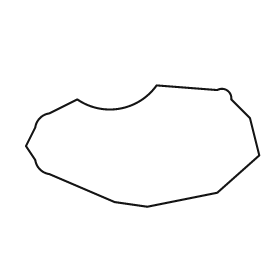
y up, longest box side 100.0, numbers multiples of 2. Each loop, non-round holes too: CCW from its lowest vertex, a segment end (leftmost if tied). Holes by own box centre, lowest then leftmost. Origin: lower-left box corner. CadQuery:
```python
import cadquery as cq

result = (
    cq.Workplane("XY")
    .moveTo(52.0, 0.0)
    .lineTo(82.0, 6.0)
    .lineTo(100.0, 22.0)
    .lineTo(96.0, 38.0)
    .lineTo(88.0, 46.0)
    .threePointArc((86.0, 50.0), (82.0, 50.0))
    .lineTo(56.0, 52.0)
    .threePointArc((40.0, 42.0), (22.0, 46.0))
    .lineTo(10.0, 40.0)
    .threePointArc((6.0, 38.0), (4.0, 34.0))
    .lineTo(0.0, 26.0)
    .lineTo(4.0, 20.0)
    .threePointArc((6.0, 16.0), (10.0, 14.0))
    .lineTo(38.0, 2.0)
    .close()
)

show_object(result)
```